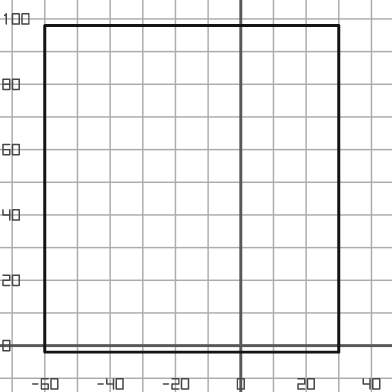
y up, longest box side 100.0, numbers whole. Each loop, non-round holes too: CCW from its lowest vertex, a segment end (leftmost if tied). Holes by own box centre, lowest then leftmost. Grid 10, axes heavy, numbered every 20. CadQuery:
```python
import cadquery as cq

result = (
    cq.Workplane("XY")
    .moveTo(-60.0, -2.0)
    .lineTo(30.0, -2.0)
    .lineTo(30.0, 98.0)
    .lineTo(-60.0, 98.0)
    .close()
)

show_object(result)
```